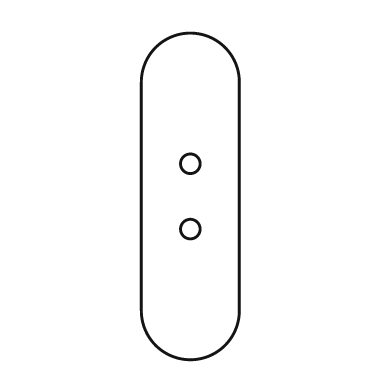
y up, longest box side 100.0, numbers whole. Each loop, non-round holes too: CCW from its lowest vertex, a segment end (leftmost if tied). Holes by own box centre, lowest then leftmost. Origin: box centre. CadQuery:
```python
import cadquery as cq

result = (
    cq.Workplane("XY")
    .moveTo(-15.0, -35.0)
    .threePointArc((0.0, -50.0), (15.0, -35.0))
    .lineTo(15.0, 35.0)
    .threePointArc((0.0, 50.0), (-15.0, 35.0))
    .close()
    .moveTo(0.0, -10.0)
    .circle(3.0)
    .moveTo(0.0, 10.0)
    .circle(3.0)
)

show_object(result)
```